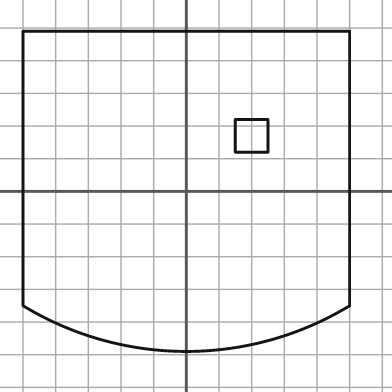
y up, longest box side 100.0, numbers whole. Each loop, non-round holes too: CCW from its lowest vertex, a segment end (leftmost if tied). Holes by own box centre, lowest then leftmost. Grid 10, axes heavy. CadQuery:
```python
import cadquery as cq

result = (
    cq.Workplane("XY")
    .moveTo(-50.0, -35.0)
    .threePointArc((0.0, -49.0), (50.0, -35.0))
    .lineTo(50.0, 49.0)
    .lineTo(-50.0, 49.0)
    .close()
    .moveTo(15.0, 12.0)
    .lineTo(25.0, 12.0)
    .lineTo(25.0, 22.0)
    .lineTo(15.0, 22.0)
    .close()
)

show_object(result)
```